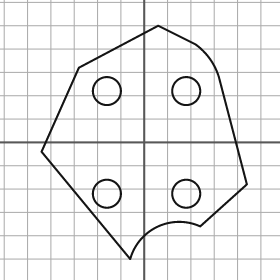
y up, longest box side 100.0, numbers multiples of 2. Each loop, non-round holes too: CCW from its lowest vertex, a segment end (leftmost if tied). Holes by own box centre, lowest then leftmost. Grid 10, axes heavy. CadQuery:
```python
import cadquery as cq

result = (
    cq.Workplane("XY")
    .moveTo(-6.0, -50.0)
    .threePointArc((6.0, -36.0), (24.0, -36.0))
    .lineTo(44.0, -18.0)
    .lineTo(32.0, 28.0)
    .threePointArc((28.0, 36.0), (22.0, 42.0))
    .lineTo(6.0, 50.0)
    .lineTo(-28.0, 32.0)
    .lineTo(-44.0, -4.0)
    .close()
    .moveTo(-16.0, -22.0)
    .circle(6.0)
    .moveTo(18.0, -22.0)
    .circle(6.0)
    .moveTo(-16.0, 22.0)
    .circle(6.0)
    .moveTo(18.0, 22.0)
    .circle(6.0)
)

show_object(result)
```